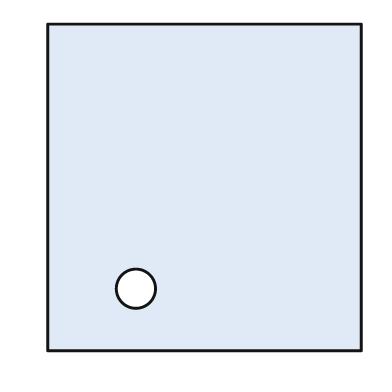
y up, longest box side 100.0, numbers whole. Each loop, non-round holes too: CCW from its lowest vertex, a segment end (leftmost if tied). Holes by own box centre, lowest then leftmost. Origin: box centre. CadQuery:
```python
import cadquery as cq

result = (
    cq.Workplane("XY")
    .moveTo(-48.0, -50.0)
    .lineTo(48.0, -50.0)
    .lineTo(48.0, 50.0)
    .lineTo(-48.0, 50.0)
    .close()
    .moveTo(-21.0, -31.0)
    .circle(6.0)
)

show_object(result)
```